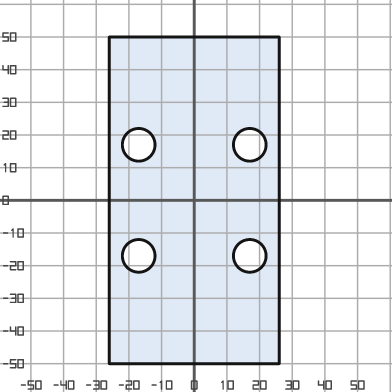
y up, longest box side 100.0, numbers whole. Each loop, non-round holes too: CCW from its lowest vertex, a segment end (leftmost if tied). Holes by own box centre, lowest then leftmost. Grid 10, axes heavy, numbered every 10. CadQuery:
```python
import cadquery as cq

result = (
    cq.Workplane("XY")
    .moveTo(-26.0, -50.0)
    .lineTo(26.0, -50.0)
    .lineTo(26.0, 50.0)
    .lineTo(-26.0, 50.0)
    .close()
    .moveTo(-17.0, -17.0)
    .circle(5.0)
    .moveTo(17.0, -17.0)
    .circle(5.0)
    .moveTo(-17.0, 17.0)
    .circle(5.0)
    .moveTo(17.0, 17.0)
    .circle(5.0)
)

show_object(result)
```